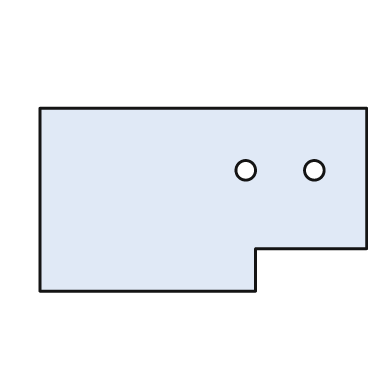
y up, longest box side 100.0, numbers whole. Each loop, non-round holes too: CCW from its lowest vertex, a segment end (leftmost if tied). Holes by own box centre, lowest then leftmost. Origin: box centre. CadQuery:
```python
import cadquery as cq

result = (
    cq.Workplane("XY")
    .moveTo(-50.0, -28.0)
    .lineTo(16.0, -28.0)
    .lineTo(16.0, -15.0)
    .lineTo(50.0, -15.0)
    .lineTo(50.0, 28.0)
    .lineTo(-50.0, 28.0)
    .close()
    .moveTo(13.0, 9.0)
    .circle(3.0)
    .moveTo(34.0, 9.0)
    .circle(3.0)
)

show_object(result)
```